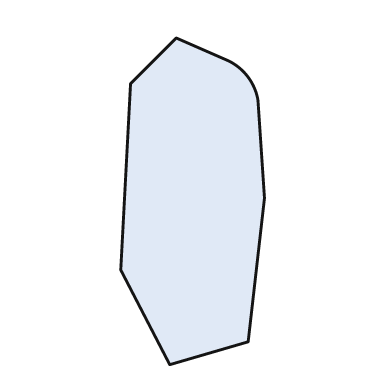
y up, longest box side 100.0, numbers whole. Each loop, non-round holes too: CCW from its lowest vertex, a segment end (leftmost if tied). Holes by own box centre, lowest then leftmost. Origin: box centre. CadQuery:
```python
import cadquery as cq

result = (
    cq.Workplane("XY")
    .moveTo(-7.0, -50.0)
    .lineTo(17.0, -43.0)
    .lineTo(22.0, 1.0)
    .lineTo(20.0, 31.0)
    .threePointArc((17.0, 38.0), (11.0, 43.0))
    .lineTo(-5.0, 50.0)
    .lineTo(-19.0, 36.0)
    .lineTo(-22.0, -21.0)
    .close()
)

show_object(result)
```